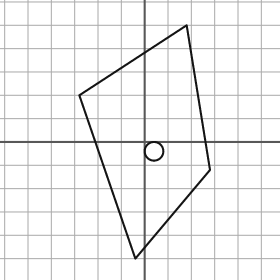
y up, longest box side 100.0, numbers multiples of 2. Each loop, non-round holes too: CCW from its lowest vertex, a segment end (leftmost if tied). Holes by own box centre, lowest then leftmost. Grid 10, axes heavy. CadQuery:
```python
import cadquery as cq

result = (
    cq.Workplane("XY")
    .moveTo(-4.0, -50.0)
    .lineTo(28.0, -12.0)
    .lineTo(18.0, 50.0)
    .lineTo(-28.0, 20.0)
    .close()
    .moveTo(4.0, -4.0)
    .circle(4.0)
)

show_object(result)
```